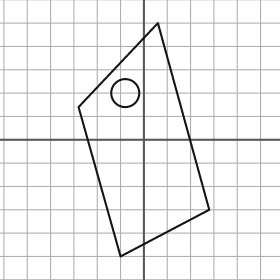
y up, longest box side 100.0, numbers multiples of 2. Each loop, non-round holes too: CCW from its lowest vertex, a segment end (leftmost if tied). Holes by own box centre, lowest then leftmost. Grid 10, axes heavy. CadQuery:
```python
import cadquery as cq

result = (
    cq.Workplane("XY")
    .moveTo(-10.0, -50.0)
    .lineTo(28.0, -30.0)
    .lineTo(6.0, 50.0)
    .lineTo(-28.0, 14.0)
    .close()
    .moveTo(-8.0, 20.0)
    .circle(6.0)
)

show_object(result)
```